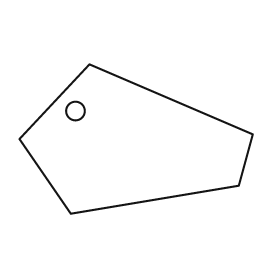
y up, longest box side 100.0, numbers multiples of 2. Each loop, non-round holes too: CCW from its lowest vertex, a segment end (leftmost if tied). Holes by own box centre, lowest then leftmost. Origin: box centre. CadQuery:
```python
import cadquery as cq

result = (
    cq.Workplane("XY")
    .moveTo(-28.0, -32.0)
    .lineTo(44.0, -20.0)
    .lineTo(50.0, 2.0)
    .lineTo(-20.0, 32.0)
    .lineTo(-50.0, 0.0)
    .close()
    .moveTo(-26.0, 12.0)
    .circle(4.0)
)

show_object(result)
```